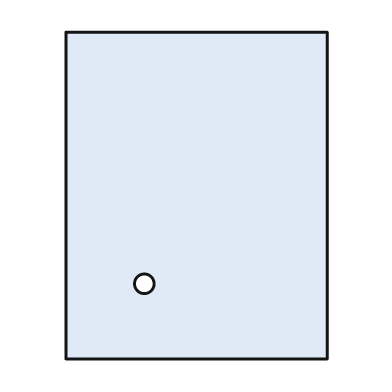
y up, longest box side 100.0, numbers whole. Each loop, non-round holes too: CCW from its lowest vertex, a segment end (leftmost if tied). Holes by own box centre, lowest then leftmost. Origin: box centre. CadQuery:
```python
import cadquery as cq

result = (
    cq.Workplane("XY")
    .moveTo(-40.0, -50.0)
    .lineTo(40.0, -50.0)
    .lineTo(40.0, 50.0)
    .lineTo(-40.0, 50.0)
    .close()
    .moveTo(-16.0, -27.0)
    .circle(3.0)
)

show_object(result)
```